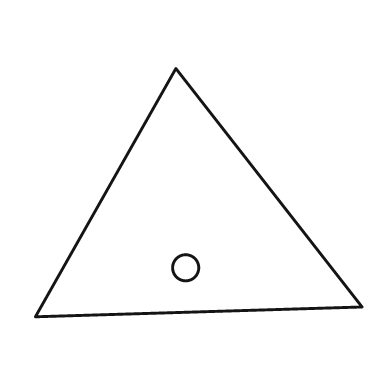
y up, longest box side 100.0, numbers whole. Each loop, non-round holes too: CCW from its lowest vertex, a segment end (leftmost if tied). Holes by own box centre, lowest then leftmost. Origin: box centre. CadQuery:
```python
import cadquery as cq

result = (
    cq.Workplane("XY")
    .moveTo(-50.0, -38.0)
    .lineTo(50.0, -35.0)
    .lineTo(-7.0, 38.0)
    .close()
    .moveTo(-4.0, -23.0)
    .circle(4.0)
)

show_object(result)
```